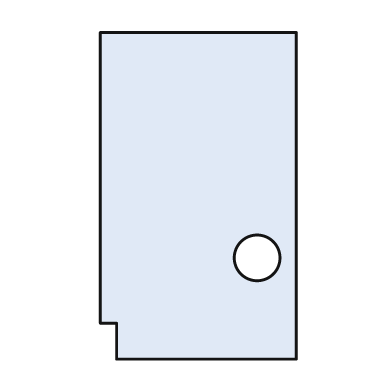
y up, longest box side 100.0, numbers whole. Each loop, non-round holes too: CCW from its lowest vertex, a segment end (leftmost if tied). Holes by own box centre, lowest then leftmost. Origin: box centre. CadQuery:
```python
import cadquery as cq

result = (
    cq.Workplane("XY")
    .moveTo(-25.0, -50.0)
    .lineTo(30.0, -50.0)
    .lineTo(30.0, 50.0)
    .lineTo(-30.0, 50.0)
    .lineTo(-30.0, -39.0)
    .lineTo(-25.0, -39.0)
    .close()
    .moveTo(18.0, -19.0)
    .circle(7.0)
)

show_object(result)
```